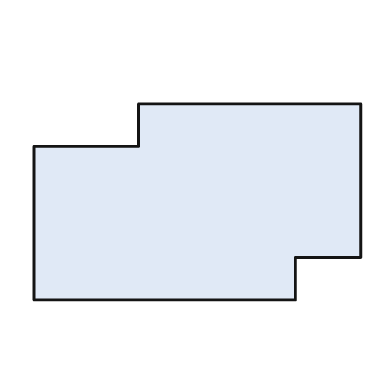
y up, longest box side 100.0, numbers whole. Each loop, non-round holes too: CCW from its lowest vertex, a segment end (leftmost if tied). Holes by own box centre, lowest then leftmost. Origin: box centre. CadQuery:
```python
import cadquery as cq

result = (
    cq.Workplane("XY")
    .moveTo(-50.0, -30.0)
    .lineTo(30.0, -30.0)
    .lineTo(30.0, -17.0)
    .lineTo(50.0, -17.0)
    .lineTo(50.0, 30.0)
    .lineTo(-18.0, 30.0)
    .lineTo(-18.0, 17.0)
    .lineTo(-50.0, 17.0)
    .close()
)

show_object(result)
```